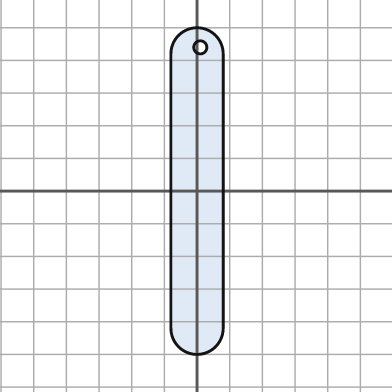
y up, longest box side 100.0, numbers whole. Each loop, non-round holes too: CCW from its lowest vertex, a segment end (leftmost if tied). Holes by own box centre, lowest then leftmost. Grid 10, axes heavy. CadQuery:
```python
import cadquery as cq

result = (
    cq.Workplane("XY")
    .moveTo(-8.0, -42.0)
    .threePointArc((0.0, -50.0), (8.0, -42.0))
    .lineTo(8.0, 42.0)
    .threePointArc((0.0, 50.0), (-8.0, 42.0))
    .close()
    .moveTo(1.0, 44.0)
    .circle(2.0)
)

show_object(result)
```